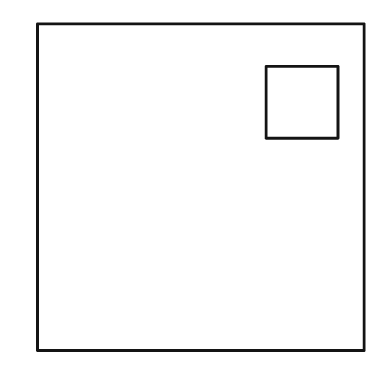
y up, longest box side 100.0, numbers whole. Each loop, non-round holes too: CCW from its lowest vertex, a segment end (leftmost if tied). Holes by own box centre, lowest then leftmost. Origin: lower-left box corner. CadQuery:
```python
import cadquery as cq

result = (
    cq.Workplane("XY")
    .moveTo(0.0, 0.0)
    .lineTo(100.0, 0.0)
    .lineTo(100.0, 100.0)
    .lineTo(0.0, 100.0)
    .close()
    .moveTo(70.0, 65.0)
    .lineTo(92.0, 65.0)
    .lineTo(92.0, 87.0)
    .lineTo(70.0, 87.0)
    .close()
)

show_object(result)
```